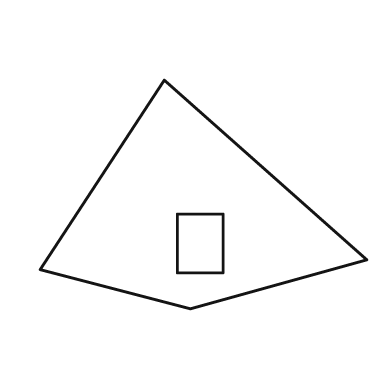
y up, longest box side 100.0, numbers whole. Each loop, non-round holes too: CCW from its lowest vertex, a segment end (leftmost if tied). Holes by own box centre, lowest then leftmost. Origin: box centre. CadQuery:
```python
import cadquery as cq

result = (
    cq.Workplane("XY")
    .moveTo(-4.0, -35.0)
    .lineTo(50.0, -20.0)
    .lineTo(-12.0, 35.0)
    .lineTo(-50.0, -23.0)
    .close()
    .moveTo(-8.0, -24.0)
    .lineTo(6.0, -24.0)
    .lineTo(6.0, -6.0)
    .lineTo(-8.0, -6.0)
    .close()
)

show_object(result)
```